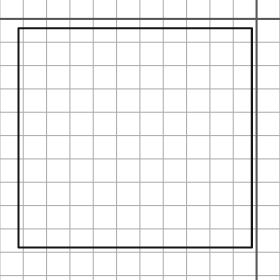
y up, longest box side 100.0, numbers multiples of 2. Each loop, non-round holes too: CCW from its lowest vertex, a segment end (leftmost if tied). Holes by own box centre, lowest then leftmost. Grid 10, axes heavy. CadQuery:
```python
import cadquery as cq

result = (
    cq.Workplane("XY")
    .moveTo(-102.0, -98.0)
    .lineTo(-2.0, -98.0)
    .lineTo(-2.0, -4.0)
    .lineTo(-102.0, -4.0)
    .close()
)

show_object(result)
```